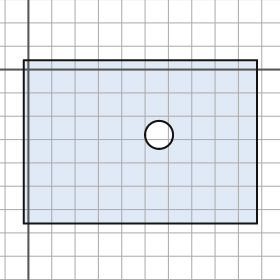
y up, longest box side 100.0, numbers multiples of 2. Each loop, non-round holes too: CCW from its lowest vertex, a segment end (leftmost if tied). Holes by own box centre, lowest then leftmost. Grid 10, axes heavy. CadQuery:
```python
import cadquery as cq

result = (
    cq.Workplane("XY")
    .moveTo(-2.0, -66.0)
    .lineTo(98.0, -66.0)
    .lineTo(98.0, 4.0)
    .lineTo(-2.0, 4.0)
    .close()
    .moveTo(56.0, -28.0)
    .circle(6.0)
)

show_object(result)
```